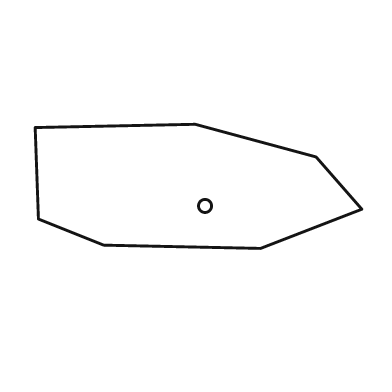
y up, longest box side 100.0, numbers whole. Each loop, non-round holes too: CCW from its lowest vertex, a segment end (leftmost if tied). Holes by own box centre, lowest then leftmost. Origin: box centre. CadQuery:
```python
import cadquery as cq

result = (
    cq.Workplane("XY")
    .moveTo(19.0, -19.0)
    .lineTo(50.0, -7.0)
    .lineTo(36.0, 9.0)
    .lineTo(-1.0, 19.0)
    .lineTo(-50.0, 18.0)
    .lineTo(-49.0, -10.0)
    .lineTo(-29.0, -18.0)
    .close()
    .moveTo(2.0, -6.0)
    .circle(2.0)
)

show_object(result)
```